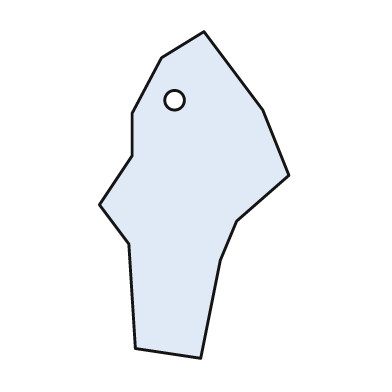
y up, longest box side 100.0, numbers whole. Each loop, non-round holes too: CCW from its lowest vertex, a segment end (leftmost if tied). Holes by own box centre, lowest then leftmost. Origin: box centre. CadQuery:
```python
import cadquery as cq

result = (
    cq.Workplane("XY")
    .moveTo(2.0, -50.0)
    .lineTo(8.0, -20.0)
    .lineTo(13.0, -8.0)
    .lineTo(29.0, 6.0)
    .lineTo(21.0, 26.0)
    .lineTo(3.0, 50.0)
    .lineTo(-10.0, 42.0)
    .lineTo(-19.0, 25.0)
    .lineTo(-19.0, 12.0)
    .lineTo(-29.0, -3.0)
    .lineTo(-20.0, -15.0)
    .lineTo(-18.0, -47.0)
    .close()
    .moveTo(-6.0, 29.0)
    .circle(3.0)
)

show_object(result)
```